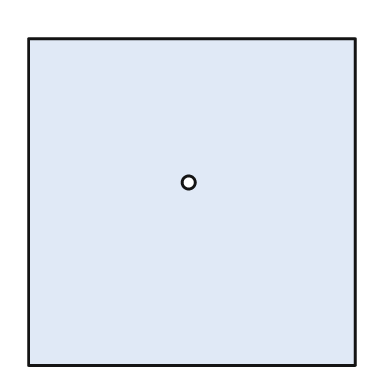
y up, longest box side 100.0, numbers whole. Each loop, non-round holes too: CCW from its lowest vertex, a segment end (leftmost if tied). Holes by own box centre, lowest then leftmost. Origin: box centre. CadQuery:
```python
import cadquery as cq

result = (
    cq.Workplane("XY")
    .moveTo(-50.0, -50.0)
    .lineTo(50.0, -50.0)
    .lineTo(50.0, 50.0)
    .lineTo(-50.0, 50.0)
    .close()
    .moveTo(-1.0, 6.0)
    .circle(2.0)
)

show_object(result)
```